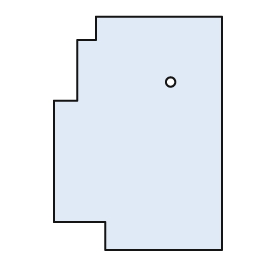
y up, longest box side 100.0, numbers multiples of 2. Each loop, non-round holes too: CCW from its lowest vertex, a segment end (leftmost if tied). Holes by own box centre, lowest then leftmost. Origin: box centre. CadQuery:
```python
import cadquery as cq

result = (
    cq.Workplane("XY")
    .moveTo(-14.0, -50.0)
    .lineTo(36.0, -50.0)
    .lineTo(36.0, 50.0)
    .lineTo(-18.0, 50.0)
    .lineTo(-18.0, 40.0)
    .lineTo(-26.0, 40.0)
    .lineTo(-26.0, 14.0)
    .lineTo(-36.0, 14.0)
    .lineTo(-36.0, -38.0)
    .lineTo(-14.0, -38.0)
    .close()
    .moveTo(14.0, 22.0)
    .circle(2.0)
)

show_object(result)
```